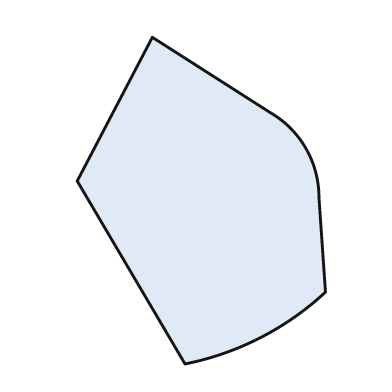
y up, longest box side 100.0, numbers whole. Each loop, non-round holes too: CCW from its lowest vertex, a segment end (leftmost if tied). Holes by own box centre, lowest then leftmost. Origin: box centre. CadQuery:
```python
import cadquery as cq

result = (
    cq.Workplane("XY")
    .moveTo(-5.0, -50.0)
    .threePointArc((18.0, -42.0), (38.0, -28.0))
    .lineTo(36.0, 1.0)
    .threePointArc((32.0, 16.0), (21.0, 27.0))
    .lineTo(-15.0, 50.0)
    .lineTo(-38.0, 6.0)
    .close()
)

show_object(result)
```